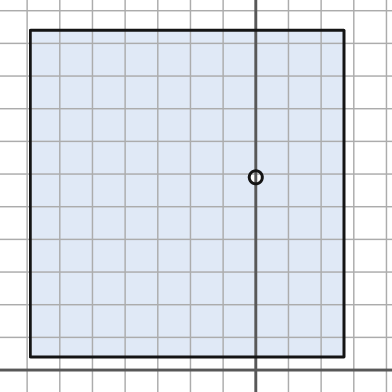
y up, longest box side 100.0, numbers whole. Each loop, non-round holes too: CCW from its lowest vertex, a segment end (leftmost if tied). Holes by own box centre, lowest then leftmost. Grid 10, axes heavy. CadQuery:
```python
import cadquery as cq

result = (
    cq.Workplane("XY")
    .moveTo(-69.0, 4.0)
    .lineTo(27.0, 4.0)
    .lineTo(27.0, 104.0)
    .lineTo(-69.0, 104.0)
    .close()
    .moveTo(0.0, 59.0)
    .circle(2.0)
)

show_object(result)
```